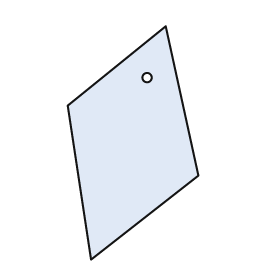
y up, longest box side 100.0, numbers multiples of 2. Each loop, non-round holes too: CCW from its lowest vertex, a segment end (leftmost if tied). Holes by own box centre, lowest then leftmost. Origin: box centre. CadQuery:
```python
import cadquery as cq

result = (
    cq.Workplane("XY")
    .moveTo(-18.0, -50.0)
    .lineTo(28.0, -14.0)
    .lineTo(14.0, 50.0)
    .lineTo(-28.0, 16.0)
    .close()
    .moveTo(6.0, 28.0)
    .circle(2.0)
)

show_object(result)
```